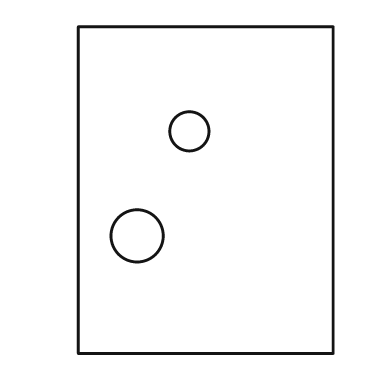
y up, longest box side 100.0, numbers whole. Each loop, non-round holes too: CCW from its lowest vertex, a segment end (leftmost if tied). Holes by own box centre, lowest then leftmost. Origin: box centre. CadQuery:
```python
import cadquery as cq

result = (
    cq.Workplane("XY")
    .moveTo(-39.0, -50.0)
    .lineTo(39.0, -50.0)
    .lineTo(39.0, 50.0)
    .lineTo(-39.0, 50.0)
    .close()
    .moveTo(-21.0, -14.0)
    .circle(8.0)
    .moveTo(-5.0, 18.0)
    .circle(6.0)
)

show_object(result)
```